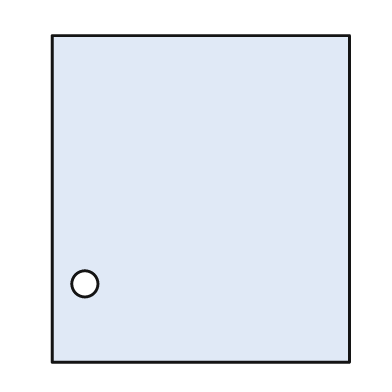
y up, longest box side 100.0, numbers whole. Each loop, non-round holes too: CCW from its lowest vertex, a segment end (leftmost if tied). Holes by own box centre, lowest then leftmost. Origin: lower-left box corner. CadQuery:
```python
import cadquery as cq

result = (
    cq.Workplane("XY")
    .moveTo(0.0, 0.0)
    .lineTo(91.0, 0.0)
    .lineTo(91.0, 100.0)
    .lineTo(0.0, 100.0)
    .close()
    .moveTo(10.0, 24.0)
    .circle(4.0)
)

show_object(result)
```